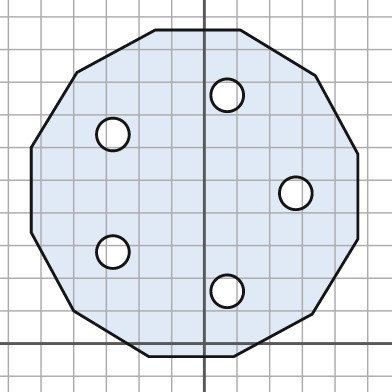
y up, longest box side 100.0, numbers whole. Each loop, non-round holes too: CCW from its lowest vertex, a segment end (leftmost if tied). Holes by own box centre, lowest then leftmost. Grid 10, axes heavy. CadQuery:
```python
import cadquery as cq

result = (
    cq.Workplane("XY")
    .moveTo(-17.0, -4.0)
    .lineTo(9.0, -4.0)
    .lineTo(33.0, 9.0)
    .lineTo(47.0, 32.0)
    .lineTo(47.0, 58.0)
    .lineTo(34.0, 82.0)
    .lineTo(11.0, 96.0)
    .lineTo(-15.0, 96.0)
    .lineTo(-39.0, 83.0)
    .lineTo(-53.0, 60.0)
    .lineTo(-53.0, 34.0)
    .lineTo(-40.0, 10.0)
    .close()
    .moveTo(7.0, 16.0)
    .circle(5.0)
    .moveTo(-28.0, 28.0)
    .circle(5.0)
    .moveTo(28.0, 46.0)
    .circle(5.0)
    .moveTo(-28.0, 64.0)
    .circle(5.0)
    .moveTo(7.0, 76.0)
    .circle(5.0)
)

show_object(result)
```